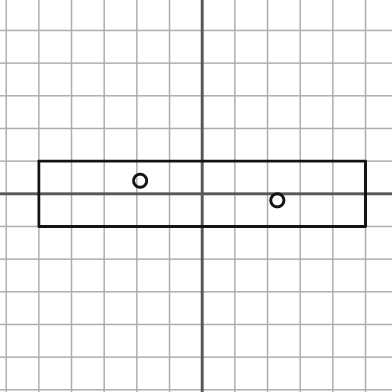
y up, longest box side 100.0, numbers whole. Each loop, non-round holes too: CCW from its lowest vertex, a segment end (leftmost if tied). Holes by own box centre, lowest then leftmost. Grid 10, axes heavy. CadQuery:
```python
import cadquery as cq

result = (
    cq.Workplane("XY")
    .moveTo(-50.0, -10.0)
    .lineTo(50.0, -10.0)
    .lineTo(50.0, 10.0)
    .lineTo(-50.0, 10.0)
    .close()
    .moveTo(23.0, -2.0)
    .circle(2.0)
    .moveTo(-19.0, 4.0)
    .circle(2.0)
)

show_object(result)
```